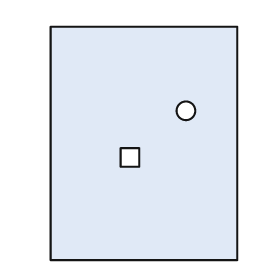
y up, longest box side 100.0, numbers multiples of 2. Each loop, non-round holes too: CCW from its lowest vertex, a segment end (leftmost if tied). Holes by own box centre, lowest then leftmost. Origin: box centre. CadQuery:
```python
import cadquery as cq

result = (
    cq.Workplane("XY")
    .moveTo(-40.0, -50.0)
    .lineTo(40.0, -50.0)
    .lineTo(40.0, 50.0)
    .lineTo(-40.0, 50.0)
    .close()
    .moveTo(-10.0, -10.0)
    .lineTo(-2.0, -10.0)
    .lineTo(-2.0, -2.0)
    .lineTo(-10.0, -2.0)
    .close()
    .moveTo(18.0, 14.0)
    .circle(4.0)
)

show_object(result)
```